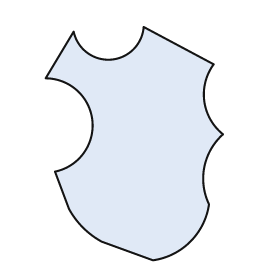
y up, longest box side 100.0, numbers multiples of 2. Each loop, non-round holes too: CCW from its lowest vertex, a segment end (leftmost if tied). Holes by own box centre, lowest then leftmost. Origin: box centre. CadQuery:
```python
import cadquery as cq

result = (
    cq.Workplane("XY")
    .moveTo(8.0, -50.0)
    .threePointArc((24.0, -42.0), (32.0, -26.0))
    .threePointArc((30.0, -10.0), (38.0, 4.0))
    .threePointArc((30.0, 18.0), (34.0, 34.0))
    .lineTo(4.0, 50.0)
    .threePointArc((-10.0, 36.0), (-26.0, 48.0))
    .lineTo(-38.0, 28.0)
    .threePointArc((-18.0, 10.0), (-34.0, -12.0))
    .lineTo(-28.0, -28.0)
    .threePointArc((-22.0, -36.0), (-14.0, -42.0))
    .close()
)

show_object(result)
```